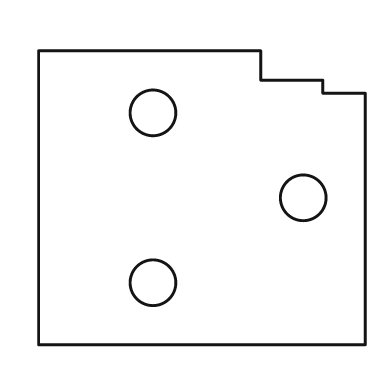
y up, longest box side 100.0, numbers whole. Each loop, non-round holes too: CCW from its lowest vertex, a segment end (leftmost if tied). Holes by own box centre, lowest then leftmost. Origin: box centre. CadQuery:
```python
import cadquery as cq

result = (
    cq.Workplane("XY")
    .moveTo(-50.0, -45.0)
    .lineTo(50.0, -45.0)
    .lineTo(50.0, 32.0)
    .lineTo(37.0, 32.0)
    .lineTo(37.0, 36.0)
    .lineTo(18.0, 36.0)
    .lineTo(18.0, 45.0)
    .lineTo(-50.0, 45.0)
    .close()
    .moveTo(-15.0, -26.0)
    .circle(7.0)
    .moveTo(31.0, 0.0)
    .circle(7.0)
    .moveTo(-15.0, 26.0)
    .circle(7.0)
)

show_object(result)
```